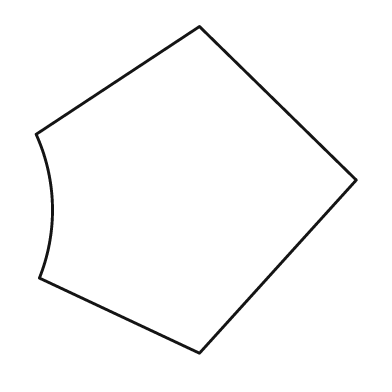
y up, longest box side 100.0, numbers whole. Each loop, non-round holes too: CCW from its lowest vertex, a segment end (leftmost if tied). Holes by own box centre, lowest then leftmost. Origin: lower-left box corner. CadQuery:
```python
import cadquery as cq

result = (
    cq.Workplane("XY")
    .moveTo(50.0, 0.0)
    .lineTo(98.0, 53.0)
    .lineTo(50.0, 100.0)
    .lineTo(0.0, 67.0)
    .threePointArc((5.0, 45.0), (1.0, 23.0))
    .close()
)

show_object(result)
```